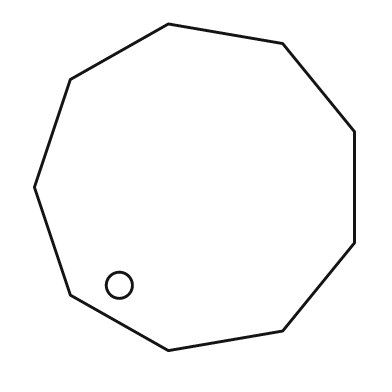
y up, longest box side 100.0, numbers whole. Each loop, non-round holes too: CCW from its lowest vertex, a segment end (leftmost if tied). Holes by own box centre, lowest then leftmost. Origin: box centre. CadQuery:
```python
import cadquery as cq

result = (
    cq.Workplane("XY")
    .moveTo(-8.0, -50.0)
    .lineTo(27.0, -44.0)
    .lineTo(49.0, -17.0)
    .lineTo(49.0, 17.0)
    .lineTo(27.0, 44.0)
    .lineTo(-8.0, 50.0)
    .lineTo(-38.0, 33.0)
    .lineTo(-49.0, 0.0)
    .lineTo(-38.0, -33.0)
    .close()
    .moveTo(-23.0, -30.0)
    .circle(4.0)
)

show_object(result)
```